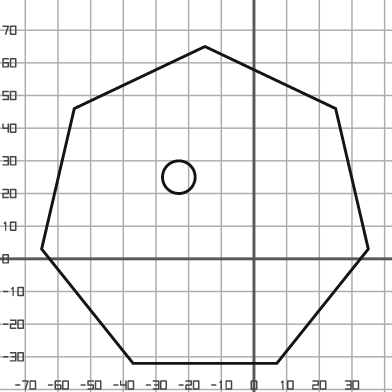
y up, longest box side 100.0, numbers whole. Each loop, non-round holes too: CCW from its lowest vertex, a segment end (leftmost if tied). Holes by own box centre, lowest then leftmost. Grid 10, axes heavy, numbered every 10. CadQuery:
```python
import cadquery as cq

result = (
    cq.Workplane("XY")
    .moveTo(-37.0, -32.0)
    .lineTo(7.0, -32.0)
    .lineTo(35.0, 3.0)
    .lineTo(25.0, 46.0)
    .lineTo(-15.0, 65.0)
    .lineTo(-55.0, 46.0)
    .lineTo(-65.0, 3.0)
    .close()
    .moveTo(-23.0, 25.0)
    .circle(5.0)
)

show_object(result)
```